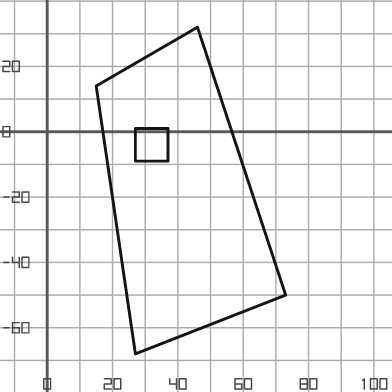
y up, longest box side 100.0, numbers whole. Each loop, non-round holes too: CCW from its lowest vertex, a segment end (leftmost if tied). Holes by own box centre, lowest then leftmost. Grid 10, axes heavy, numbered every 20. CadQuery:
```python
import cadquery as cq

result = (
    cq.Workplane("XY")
    .moveTo(27.0, -68.0)
    .lineTo(73.0, -50.0)
    .lineTo(46.0, 32.0)
    .lineTo(15.0, 14.0)
    .close()
    .moveTo(27.0, -9.0)
    .lineTo(37.0, -9.0)
    .lineTo(37.0, 1.0)
    .lineTo(27.0, 1.0)
    .close()
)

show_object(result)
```